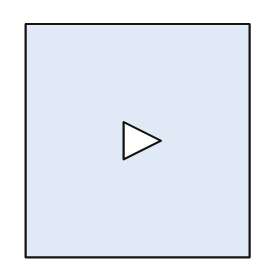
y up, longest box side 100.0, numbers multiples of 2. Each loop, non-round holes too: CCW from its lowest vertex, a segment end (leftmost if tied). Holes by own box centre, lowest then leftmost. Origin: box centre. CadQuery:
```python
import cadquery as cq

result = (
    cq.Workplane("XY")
    .moveTo(-48.0, -50.0)
    .lineTo(48.0, -50.0)
    .lineTo(48.0, 50.0)
    .lineTo(-48.0, 50.0)
    .close()
    .moveTo(-6.0, -8.0)
    .lineTo(10.0, 0.0)
    .lineTo(-6.0, 8.0)
    .close()
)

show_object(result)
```